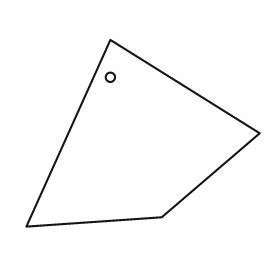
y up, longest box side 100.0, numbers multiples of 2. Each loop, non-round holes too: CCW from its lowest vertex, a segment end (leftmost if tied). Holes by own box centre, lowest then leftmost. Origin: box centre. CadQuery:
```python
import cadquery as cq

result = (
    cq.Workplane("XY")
    .moveTo(-50.0, -40.0)
    .lineTo(8.0, -36.0)
    .lineTo(50.0, 0.0)
    .lineTo(-14.0, 40.0)
    .close()
    .moveTo(-14.0, 24.0)
    .circle(2.0)
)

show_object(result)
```